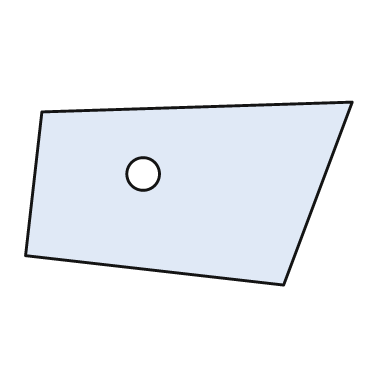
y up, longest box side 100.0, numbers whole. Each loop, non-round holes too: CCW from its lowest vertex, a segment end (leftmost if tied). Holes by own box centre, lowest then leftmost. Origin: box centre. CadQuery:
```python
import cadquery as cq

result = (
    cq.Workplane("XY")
    .moveTo(29.0, -28.0)
    .lineTo(50.0, 28.0)
    .lineTo(-45.0, 25.0)
    .lineTo(-50.0, -19.0)
    .close()
    .moveTo(-14.0, 6.0)
    .circle(5.0)
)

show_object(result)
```